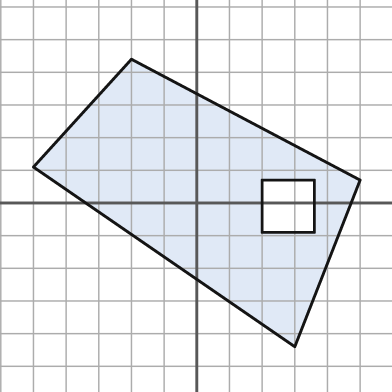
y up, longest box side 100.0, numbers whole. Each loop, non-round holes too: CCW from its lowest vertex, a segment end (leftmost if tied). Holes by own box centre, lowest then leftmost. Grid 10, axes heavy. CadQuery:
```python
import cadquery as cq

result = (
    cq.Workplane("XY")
    .moveTo(30.0, -44.0)
    .lineTo(50.0, 7.0)
    .lineTo(-20.0, 44.0)
    .lineTo(-50.0, 11.0)
    .close()
    .moveTo(20.0, -9.0)
    .lineTo(36.0, -9.0)
    .lineTo(36.0, 7.0)
    .lineTo(20.0, 7.0)
    .close()
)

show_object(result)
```